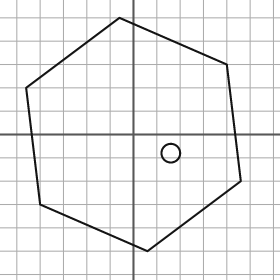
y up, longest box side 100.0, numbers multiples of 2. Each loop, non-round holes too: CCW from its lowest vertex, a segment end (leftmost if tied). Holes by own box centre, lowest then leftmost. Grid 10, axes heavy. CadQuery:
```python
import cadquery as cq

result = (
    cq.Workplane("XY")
    .moveTo(6.0, -50.0)
    .lineTo(46.0, -20.0)
    .lineTo(40.0, 30.0)
    .lineTo(-6.0, 50.0)
    .lineTo(-46.0, 20.0)
    .lineTo(-40.0, -30.0)
    .close()
    .moveTo(16.0, -8.0)
    .circle(4.0)
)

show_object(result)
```